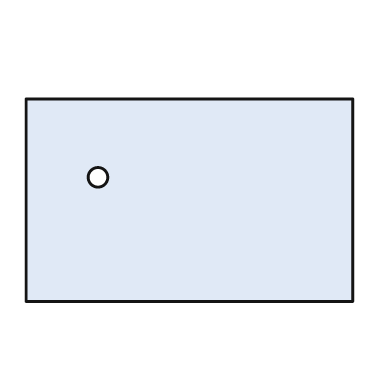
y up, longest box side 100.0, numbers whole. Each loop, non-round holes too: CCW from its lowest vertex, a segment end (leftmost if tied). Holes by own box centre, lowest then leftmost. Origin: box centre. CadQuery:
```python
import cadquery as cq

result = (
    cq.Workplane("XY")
    .moveTo(-50.0, -31.0)
    .lineTo(50.0, -31.0)
    .lineTo(50.0, 31.0)
    .lineTo(-50.0, 31.0)
    .close()
    .moveTo(-28.0, 7.0)
    .circle(3.0)
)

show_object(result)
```